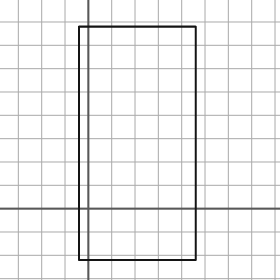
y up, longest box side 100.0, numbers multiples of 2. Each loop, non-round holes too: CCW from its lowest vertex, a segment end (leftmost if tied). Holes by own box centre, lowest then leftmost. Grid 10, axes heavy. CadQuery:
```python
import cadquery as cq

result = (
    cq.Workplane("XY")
    .moveTo(-4.0, -22.0)
    .lineTo(46.0, -22.0)
    .lineTo(46.0, 78.0)
    .lineTo(-4.0, 78.0)
    .close()
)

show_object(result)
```